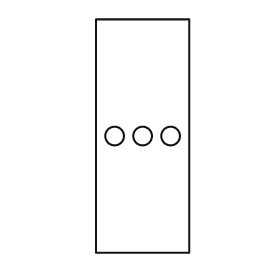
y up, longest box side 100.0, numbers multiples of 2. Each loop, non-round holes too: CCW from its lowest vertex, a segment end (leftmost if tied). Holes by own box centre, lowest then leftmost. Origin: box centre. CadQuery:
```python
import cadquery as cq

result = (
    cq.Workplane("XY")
    .moveTo(-20.0, -50.0)
    .lineTo(20.0, -50.0)
    .lineTo(20.0, 50.0)
    .lineTo(-20.0, 50.0)
    .close()
    .moveTo(-12.0, 0.0)
    .circle(4.0)
    .moveTo(0.0, 0.0)
    .circle(4.0)
    .moveTo(12.0, 0.0)
    .circle(4.0)
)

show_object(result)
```